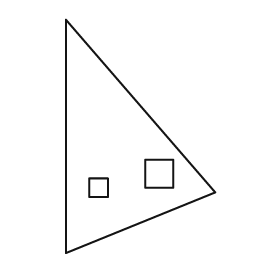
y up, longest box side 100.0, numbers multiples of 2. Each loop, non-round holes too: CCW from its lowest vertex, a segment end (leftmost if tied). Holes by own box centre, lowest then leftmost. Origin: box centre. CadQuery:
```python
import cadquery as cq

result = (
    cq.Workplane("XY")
    .moveTo(-32.0, -50.0)
    .lineTo(32.0, -24.0)
    .lineTo(-32.0, 50.0)
    .close()
    .moveTo(-22.0, -26.0)
    .lineTo(-14.0, -26.0)
    .lineTo(-14.0, -18.0)
    .lineTo(-22.0, -18.0)
    .close()
    .moveTo(2.0, -22.0)
    .lineTo(14.0, -22.0)
    .lineTo(14.0, -10.0)
    .lineTo(2.0, -10.0)
    .close()
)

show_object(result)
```